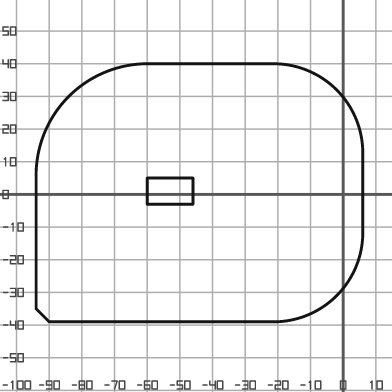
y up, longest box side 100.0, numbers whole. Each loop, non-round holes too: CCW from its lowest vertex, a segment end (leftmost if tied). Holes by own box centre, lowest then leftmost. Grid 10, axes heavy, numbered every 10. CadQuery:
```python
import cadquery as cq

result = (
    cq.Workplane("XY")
    .moveTo(-90.0, -39.0)
    .lineTo(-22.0, -39.0)
    .threePointArc((-2.0, -31.0), (6.0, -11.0))
    .lineTo(6.0, 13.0)
    .threePointArc((-2.0, 32.0), (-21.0, 40.0))
    .lineTo(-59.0, 40.0)
    .threePointArc((-84.0, 30.0), (-94.0, 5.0))
    .lineTo(-94.0, -35.0)
    .close()
    .moveTo(-60.0, -3.0)
    .lineTo(-46.0, -3.0)
    .lineTo(-46.0, 5.0)
    .lineTo(-60.0, 5.0)
    .close()
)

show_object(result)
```